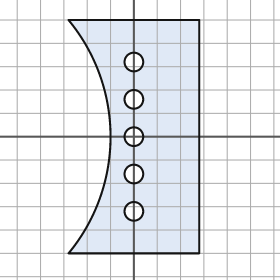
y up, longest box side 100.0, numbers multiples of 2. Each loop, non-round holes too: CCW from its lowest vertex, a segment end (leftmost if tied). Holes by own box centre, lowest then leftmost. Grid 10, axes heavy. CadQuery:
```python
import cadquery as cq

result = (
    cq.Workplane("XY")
    .moveTo(-28.0, -50.0)
    .lineTo(28.0, -50.0)
    .lineTo(28.0, 50.0)
    .lineTo(-28.0, 50.0)
    .threePointArc((-10.0, 0.0), (-28.0, -50.0))
    .close()
    .moveTo(0.0, -32.0)
    .circle(4.0)
    .moveTo(0.0, -16.0)
    .circle(4.0)
    .moveTo(0.0, 0.0)
    .circle(4.0)
    .moveTo(0.0, 16.0)
    .circle(4.0)
    .moveTo(0.0, 32.0)
    .circle(4.0)
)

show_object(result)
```